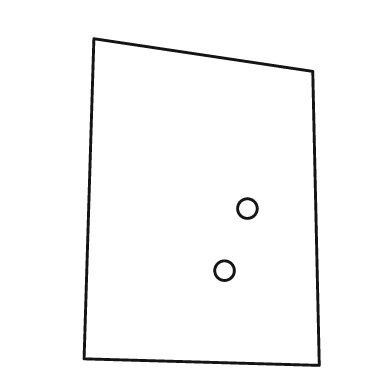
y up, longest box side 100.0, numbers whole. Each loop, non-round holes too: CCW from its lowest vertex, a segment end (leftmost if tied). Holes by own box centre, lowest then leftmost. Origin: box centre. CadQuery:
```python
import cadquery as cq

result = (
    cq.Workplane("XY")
    .moveTo(36.0, -50.0)
    .lineTo(34.0, 40.0)
    .lineTo(-33.0, 50.0)
    .lineTo(-36.0, -48.0)
    .close()
    .moveTo(7.0, -21.0)
    .circle(3.0)
    .moveTo(14.0, -2.0)
    .circle(3.0)
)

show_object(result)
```